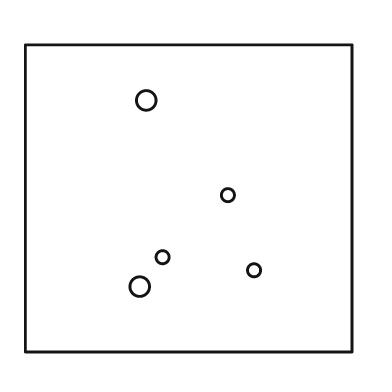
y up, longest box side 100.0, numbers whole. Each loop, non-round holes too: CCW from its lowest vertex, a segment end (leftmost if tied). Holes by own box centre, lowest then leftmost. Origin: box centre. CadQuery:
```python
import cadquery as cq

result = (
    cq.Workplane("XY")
    .moveTo(-50.0, -47.0)
    .lineTo(50.0, -47.0)
    .lineTo(50.0, 47.0)
    .lineTo(-50.0, 47.0)
    .close()
    .moveTo(-15.0, -27.0)
    .circle(3.0)
    .moveTo(20.0, -22.0)
    .circle(2.0)
    .moveTo(-8.0, -18.0)
    .circle(2.0)
    .moveTo(12.0, 1.0)
    .circle(2.0)
    .moveTo(-13.0, 30.0)
    .circle(3.0)
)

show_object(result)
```